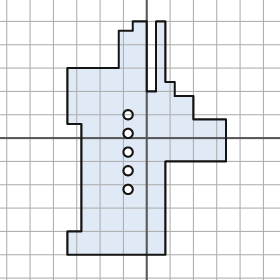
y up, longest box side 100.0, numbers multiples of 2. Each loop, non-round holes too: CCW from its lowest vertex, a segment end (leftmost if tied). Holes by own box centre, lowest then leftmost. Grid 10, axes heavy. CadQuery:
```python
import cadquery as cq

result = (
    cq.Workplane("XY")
    .moveTo(-34.0, -50.0)
    .lineTo(8.0, -50.0)
    .lineTo(8.0, -10.0)
    .lineTo(34.0, -10.0)
    .lineTo(34.0, 8.0)
    .lineTo(20.0, 8.0)
    .lineTo(20.0, 18.0)
    .lineTo(12.0, 18.0)
    .lineTo(12.0, 24.0)
    .lineTo(8.0, 24.0)
    .lineTo(8.0, 50.0)
    .lineTo(4.0, 50.0)
    .lineTo(4.0, 20.0)
    .lineTo(0.0, 20.0)
    .lineTo(0.0, 50.0)
    .lineTo(-6.0, 50.0)
    .lineTo(-6.0, 46.0)
    .lineTo(-12.0, 46.0)
    .lineTo(-12.0, 30.0)
    .lineTo(-34.0, 30.0)
    .lineTo(-34.0, 6.0)
    .lineTo(-28.0, 6.0)
    .lineTo(-28.0, -40.0)
    .lineTo(-34.0, -40.0)
    .close()
    .moveTo(-8.0, -22.0)
    .circle(2.0)
    .moveTo(-8.0, -14.0)
    .circle(2.0)
    .moveTo(-8.0, -6.0)
    .circle(2.0)
    .moveTo(-8.0, 2.0)
    .circle(2.0)
    .moveTo(-8.0, 10.0)
    .circle(2.0)
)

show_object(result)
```